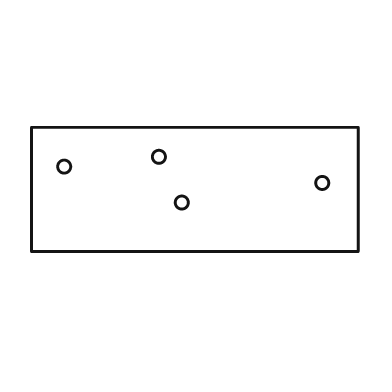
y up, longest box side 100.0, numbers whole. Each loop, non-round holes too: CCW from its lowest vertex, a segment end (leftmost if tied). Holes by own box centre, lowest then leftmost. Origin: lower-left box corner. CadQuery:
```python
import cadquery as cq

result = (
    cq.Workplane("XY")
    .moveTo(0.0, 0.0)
    .lineTo(100.0, 0.0)
    .lineTo(100.0, 38.0)
    .lineTo(0.0, 38.0)
    .close()
    .moveTo(46.0, 15.0)
    .circle(2.0)
    .moveTo(89.0, 21.0)
    .circle(2.0)
    .moveTo(10.0, 26.0)
    .circle(2.0)
    .moveTo(39.0, 29.0)
    .circle(2.0)
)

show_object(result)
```